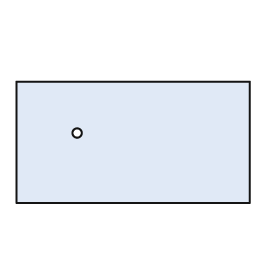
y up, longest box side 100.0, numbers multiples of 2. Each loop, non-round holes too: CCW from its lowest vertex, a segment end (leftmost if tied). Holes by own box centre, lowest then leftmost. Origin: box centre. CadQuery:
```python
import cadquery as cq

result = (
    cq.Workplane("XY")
    .moveTo(-50.0, -26.0)
    .lineTo(50.0, -26.0)
    .lineTo(50.0, 26.0)
    .lineTo(-50.0, 26.0)
    .close()
    .moveTo(-24.0, 4.0)
    .circle(2.0)
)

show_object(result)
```